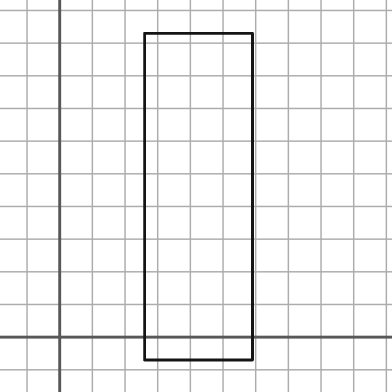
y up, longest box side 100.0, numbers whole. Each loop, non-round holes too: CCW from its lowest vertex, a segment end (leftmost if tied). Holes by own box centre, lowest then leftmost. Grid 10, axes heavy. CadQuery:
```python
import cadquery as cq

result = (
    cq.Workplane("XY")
    .moveTo(26.0, -7.0)
    .lineTo(59.0, -7.0)
    .lineTo(59.0, 93.0)
    .lineTo(26.0, 93.0)
    .close()
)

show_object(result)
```